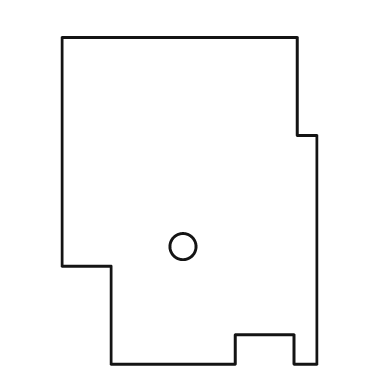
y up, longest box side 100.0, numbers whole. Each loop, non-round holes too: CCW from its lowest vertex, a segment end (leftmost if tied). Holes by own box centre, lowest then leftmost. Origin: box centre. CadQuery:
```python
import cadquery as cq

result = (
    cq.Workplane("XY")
    .moveTo(-24.0, -50.0)
    .lineTo(14.0, -50.0)
    .lineTo(14.0, -41.0)
    .lineTo(32.0, -41.0)
    .lineTo(32.0, -50.0)
    .lineTo(39.0, -50.0)
    .lineTo(39.0, 20.0)
    .lineTo(33.0, 20.0)
    .lineTo(33.0, 50.0)
    .lineTo(-39.0, 50.0)
    .lineTo(-39.0, -20.0)
    .lineTo(-24.0, -20.0)
    .close()
    .moveTo(-2.0, -14.0)
    .circle(4.0)
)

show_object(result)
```